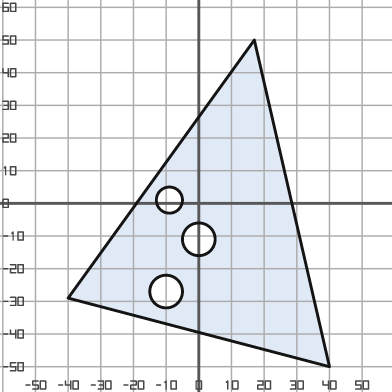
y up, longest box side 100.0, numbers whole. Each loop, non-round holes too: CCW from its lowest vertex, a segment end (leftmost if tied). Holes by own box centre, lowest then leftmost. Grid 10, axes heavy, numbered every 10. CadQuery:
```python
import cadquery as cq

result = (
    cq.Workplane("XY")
    .moveTo(40.0, -50.0)
    .lineTo(17.0, 50.0)
    .lineTo(-40.0, -29.0)
    .close()
    .moveTo(-10.0, -27.0)
    .circle(5.0)
    .moveTo(0.0, -11.0)
    .circle(5.0)
    .moveTo(-9.0, 1.0)
    .circle(4.0)
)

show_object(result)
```